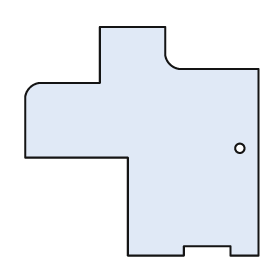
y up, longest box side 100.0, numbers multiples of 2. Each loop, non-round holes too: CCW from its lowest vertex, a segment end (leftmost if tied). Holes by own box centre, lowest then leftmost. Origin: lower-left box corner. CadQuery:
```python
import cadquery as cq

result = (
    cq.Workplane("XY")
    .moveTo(44.0, 0.0)
    .lineTo(68.0, 0.0)
    .lineTo(68.0, 4.0)
    .lineTo(88.0, 4.0)
    .lineTo(88.0, 0.0)
    .lineTo(100.0, 0.0)
    .lineTo(100.0, 80.0)
    .lineTo(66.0, 80.0)
    .threePointArc((62.0, 82.0), (60.0, 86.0))
    .lineTo(60.0, 98.0)
    .lineTo(32.0, 98.0)
    .lineTo(32.0, 74.0)
    .lineTo(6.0, 74.0)
    .threePointArc((2.0, 72.0), (0.0, 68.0))
    .lineTo(0.0, 42.0)
    .lineTo(44.0, 42.0)
    .close()
    .moveTo(92.0, 46.0)
    .circle(2.0)
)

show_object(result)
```